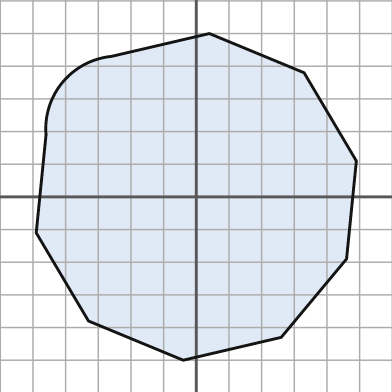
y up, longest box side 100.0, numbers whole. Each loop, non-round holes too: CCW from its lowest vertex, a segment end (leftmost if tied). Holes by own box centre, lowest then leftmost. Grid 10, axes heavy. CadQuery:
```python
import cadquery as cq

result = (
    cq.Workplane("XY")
    .moveTo(-4.0, -50.0)
    .lineTo(26.0, -43.0)
    .lineTo(46.0, -19.0)
    .lineTo(49.0, 11.0)
    .lineTo(33.0, 38.0)
    .lineTo(4.0, 50.0)
    .lineTo(-26.0, 43.0)
    .threePointArc((-41.0, 35.0), (-46.0, 19.0))
    .lineTo(-49.0, -11.0)
    .lineTo(-33.0, -38.0)
    .close()
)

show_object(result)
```